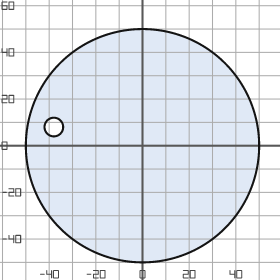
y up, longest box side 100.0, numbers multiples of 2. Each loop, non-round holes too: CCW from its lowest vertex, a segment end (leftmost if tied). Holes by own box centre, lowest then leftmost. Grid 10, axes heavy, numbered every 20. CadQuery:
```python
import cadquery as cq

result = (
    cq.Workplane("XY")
    .moveTo(0.0, 0.0)
    .circle(50.0)
    .moveTo(-38.0, 8.0)
    .circle(4.0)
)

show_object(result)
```